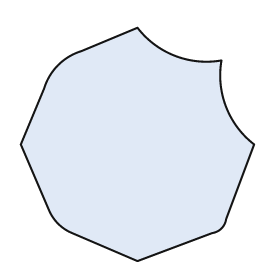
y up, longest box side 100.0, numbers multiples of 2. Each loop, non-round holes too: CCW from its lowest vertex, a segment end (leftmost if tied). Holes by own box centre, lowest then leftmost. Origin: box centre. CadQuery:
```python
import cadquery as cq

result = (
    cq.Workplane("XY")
    .moveTo(0.0, -50.0)
    .lineTo(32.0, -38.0)
    .threePointArc((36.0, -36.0), (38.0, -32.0))
    .lineTo(50.0, 0.0)
    .threePointArc((38.0, 16.0), (36.0, 36.0))
    .threePointArc((16.0, 38.0), (0.0, 50.0))
    .lineTo(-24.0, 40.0)
    .threePointArc((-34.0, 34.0), (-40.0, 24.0))
    .lineTo(-50.0, 0.0)
    .lineTo(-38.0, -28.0)
    .threePointArc((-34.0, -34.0), (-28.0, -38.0))
    .close()
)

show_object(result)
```